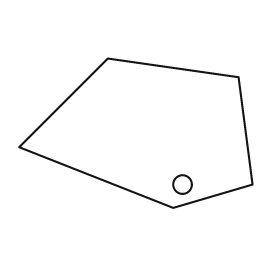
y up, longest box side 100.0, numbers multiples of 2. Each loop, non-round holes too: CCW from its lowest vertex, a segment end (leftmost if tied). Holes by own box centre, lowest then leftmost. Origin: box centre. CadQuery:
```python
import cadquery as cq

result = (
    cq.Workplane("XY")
    .moveTo(16.0, -32.0)
    .lineTo(50.0, -22.0)
    .lineTo(44.0, 24.0)
    .lineTo(-12.0, 32.0)
    .lineTo(-50.0, -6.0)
    .close()
    .moveTo(20.0, -22.0)
    .circle(4.0)
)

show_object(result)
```